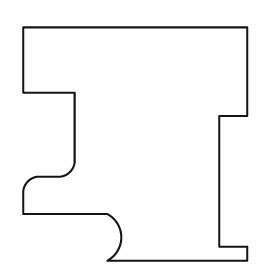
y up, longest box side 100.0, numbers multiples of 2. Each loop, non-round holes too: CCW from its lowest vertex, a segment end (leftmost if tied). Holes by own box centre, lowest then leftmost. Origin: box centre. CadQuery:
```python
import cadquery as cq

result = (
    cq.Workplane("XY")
    .moveTo(-12.0, -50.0)
    .lineTo(48.0, -50.0)
    .lineTo(48.0, -44.0)
    .lineTo(36.0, -44.0)
    .lineTo(36.0, 12.0)
    .lineTo(48.0, 12.0)
    .lineTo(48.0, 50.0)
    .lineTo(-48.0, 50.0)
    .lineTo(-48.0, 22.0)
    .lineTo(-26.0, 22.0)
    .lineTo(-26.0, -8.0)
    .threePointArc((-28.0, -12.0), (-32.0, -14.0))
    .lineTo(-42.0, -14.0)
    .threePointArc((-46.0, -16.0), (-48.0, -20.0))
    .lineTo(-48.0, -30.0)
    .lineTo(-12.0, -30.0)
    .threePointArc((-6.0, -40.0), (-12.0, -50.0))
    .close()
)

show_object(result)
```